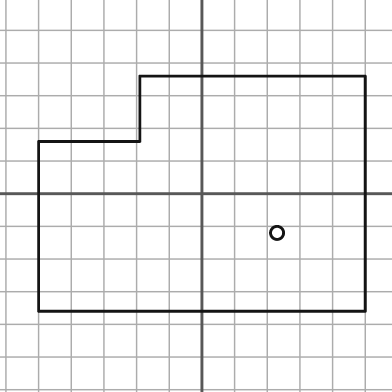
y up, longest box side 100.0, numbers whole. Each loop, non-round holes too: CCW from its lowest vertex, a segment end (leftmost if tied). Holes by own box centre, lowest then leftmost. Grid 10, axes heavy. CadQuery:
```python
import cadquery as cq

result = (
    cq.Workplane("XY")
    .moveTo(-50.0, -36.0)
    .lineTo(50.0, -36.0)
    .lineTo(50.0, 36.0)
    .lineTo(-19.0, 36.0)
    .lineTo(-19.0, 16.0)
    .lineTo(-50.0, 16.0)
    .close()
    .moveTo(23.0, -12.0)
    .circle(2.0)
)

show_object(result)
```